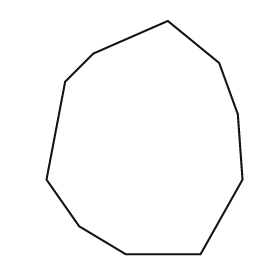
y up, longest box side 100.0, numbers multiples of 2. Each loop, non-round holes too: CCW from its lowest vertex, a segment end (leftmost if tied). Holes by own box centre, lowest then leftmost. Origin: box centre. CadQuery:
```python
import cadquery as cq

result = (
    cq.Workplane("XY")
    .moveTo(-8.0, -50.0)
    .lineTo(24.0, -50.0)
    .lineTo(42.0, -18.0)
    .lineTo(40.0, 10.0)
    .lineTo(32.0, 32.0)
    .lineTo(10.0, 50.0)
    .lineTo(-22.0, 36.0)
    .lineTo(-34.0, 24.0)
    .lineTo(-42.0, -18.0)
    .lineTo(-28.0, -38.0)
    .close()
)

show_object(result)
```